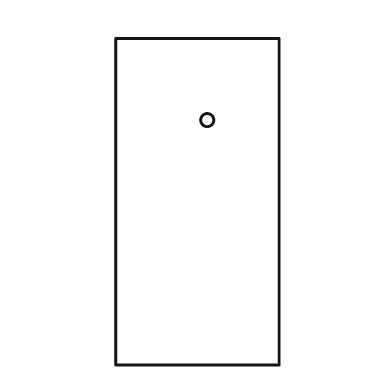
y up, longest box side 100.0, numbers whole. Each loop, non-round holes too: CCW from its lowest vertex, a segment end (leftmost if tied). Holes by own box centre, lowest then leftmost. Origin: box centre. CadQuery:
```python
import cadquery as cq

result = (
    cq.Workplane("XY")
    .moveTo(-25.0, -50.0)
    .lineTo(25.0, -50.0)
    .lineTo(25.0, 50.0)
    .lineTo(-25.0, 50.0)
    .close()
    .moveTo(3.0, 25.0)
    .circle(2.0)
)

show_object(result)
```